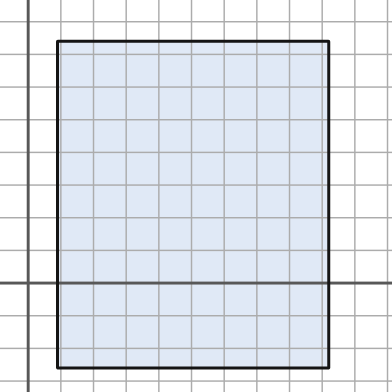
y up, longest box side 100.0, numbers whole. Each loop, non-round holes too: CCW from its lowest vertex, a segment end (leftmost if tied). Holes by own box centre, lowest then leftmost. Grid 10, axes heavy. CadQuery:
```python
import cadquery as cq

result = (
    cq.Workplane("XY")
    .moveTo(9.0, -26.0)
    .lineTo(92.0, -26.0)
    .lineTo(92.0, 74.0)
    .lineTo(9.0, 74.0)
    .close()
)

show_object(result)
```